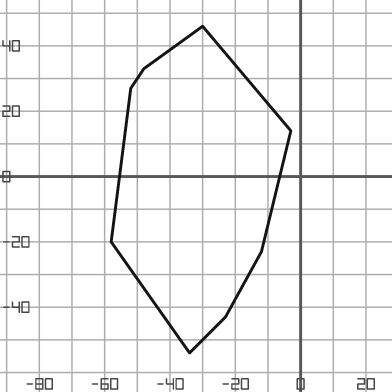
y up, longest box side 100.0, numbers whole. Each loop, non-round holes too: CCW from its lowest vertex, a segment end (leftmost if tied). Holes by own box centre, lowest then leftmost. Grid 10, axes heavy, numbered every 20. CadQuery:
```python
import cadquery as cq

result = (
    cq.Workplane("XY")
    .moveTo(-34.0, -54.0)
    .lineTo(-23.0, -43.0)
    .lineTo(-12.0, -23.0)
    .lineTo(-3.0, 14.0)
    .lineTo(-30.0, 46.0)
    .lineTo(-48.0, 33.0)
    .lineTo(-52.0, 27.0)
    .lineTo(-58.0, -20.0)
    .close()
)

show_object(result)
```